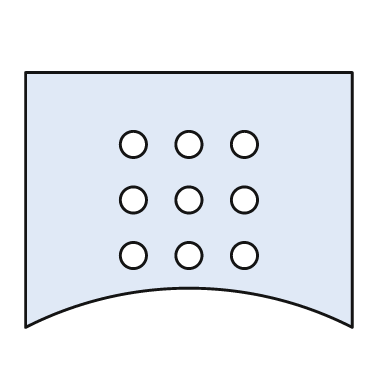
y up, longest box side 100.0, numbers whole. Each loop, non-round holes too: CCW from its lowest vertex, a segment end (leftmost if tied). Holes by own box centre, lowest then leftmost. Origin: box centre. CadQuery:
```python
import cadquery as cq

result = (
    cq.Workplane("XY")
    .moveTo(-50.0, -39.0)
    .threePointArc((0.0, -27.0), (50.0, -39.0))
    .lineTo(50.0, 39.0)
    .lineTo(-50.0, 39.0)
    .close()
    .moveTo(-17.0, -17.0)
    .circle(4.0)
    .moveTo(0.0, -17.0)
    .circle(4.0)
    .moveTo(17.0, -17.0)
    .circle(4.0)
    .moveTo(-17.0, 0.0)
    .circle(4.0)
    .moveTo(0.0, 0.0)
    .circle(4.0)
    .moveTo(17.0, 0.0)
    .circle(4.0)
    .moveTo(-17.0, 17.0)
    .circle(4.0)
    .moveTo(0.0, 17.0)
    .circle(4.0)
    .moveTo(17.0, 17.0)
    .circle(4.0)
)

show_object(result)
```